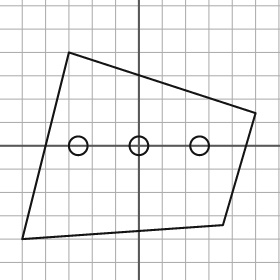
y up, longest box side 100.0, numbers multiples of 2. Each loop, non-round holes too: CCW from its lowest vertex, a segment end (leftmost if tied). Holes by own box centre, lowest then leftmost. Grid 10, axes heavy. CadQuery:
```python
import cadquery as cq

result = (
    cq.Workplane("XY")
    .moveTo(-50.0, -40.0)
    .lineTo(36.0, -34.0)
    .lineTo(50.0, 14.0)
    .lineTo(-30.0, 40.0)
    .close()
    .moveTo(-26.0, 0.0)
    .circle(4.0)
    .moveTo(0.0, 0.0)
    .circle(4.0)
    .moveTo(26.0, 0.0)
    .circle(4.0)
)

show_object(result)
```